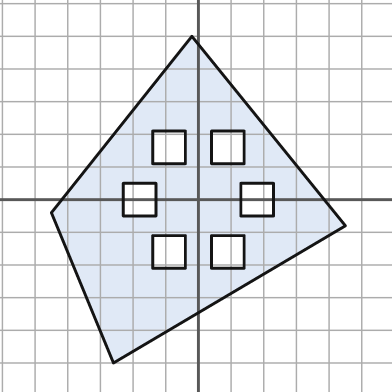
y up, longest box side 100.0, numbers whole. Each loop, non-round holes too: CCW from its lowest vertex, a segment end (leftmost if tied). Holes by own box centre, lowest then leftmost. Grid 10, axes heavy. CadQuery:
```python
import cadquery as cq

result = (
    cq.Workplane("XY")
    .moveTo(-26.0, -50.0)
    .lineTo(45.0, -8.0)
    .lineTo(-2.0, 50.0)
    .lineTo(-45.0, -4.0)
    .close()
    .moveTo(-14.0, -21.0)
    .lineTo(-4.0, -21.0)
    .lineTo(-4.0, -11.0)
    .lineTo(-14.0, -11.0)
    .close()
    .moveTo(4.0, -21.0)
    .lineTo(14.0, -21.0)
    .lineTo(14.0, -11.0)
    .lineTo(4.0, -11.0)
    .close()
    .moveTo(-23.0, -5.0)
    .lineTo(-13.0, -5.0)
    .lineTo(-13.0, 5.0)
    .lineTo(-23.0, 5.0)
    .close()
    .moveTo(13.0, -5.0)
    .lineTo(23.0, -5.0)
    .lineTo(23.0, 5.0)
    .lineTo(13.0, 5.0)
    .close()
    .moveTo(-14.0, 11.0)
    .lineTo(-4.0, 11.0)
    .lineTo(-4.0, 21.0)
    .lineTo(-14.0, 21.0)
    .close()
    .moveTo(4.0, 11.0)
    .lineTo(14.0, 11.0)
    .lineTo(14.0, 21.0)
    .lineTo(4.0, 21.0)
    .close()
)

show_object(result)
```